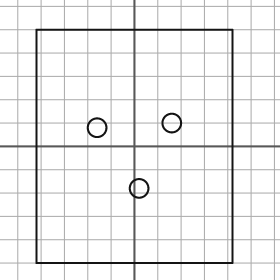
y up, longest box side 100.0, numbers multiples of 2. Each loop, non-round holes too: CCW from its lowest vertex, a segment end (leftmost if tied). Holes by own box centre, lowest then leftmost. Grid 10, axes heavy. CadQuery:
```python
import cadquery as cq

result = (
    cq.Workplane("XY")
    .moveTo(-42.0, -50.0)
    .lineTo(42.0, -50.0)
    .lineTo(42.0, 50.0)
    .lineTo(-42.0, 50.0)
    .close()
    .moveTo(2.0, -18.0)
    .circle(4.0)
    .moveTo(-16.0, 8.0)
    .circle(4.0)
    .moveTo(16.0, 10.0)
    .circle(4.0)
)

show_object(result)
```